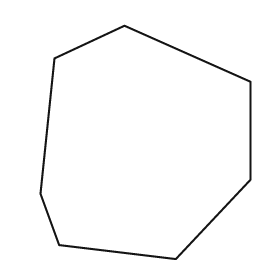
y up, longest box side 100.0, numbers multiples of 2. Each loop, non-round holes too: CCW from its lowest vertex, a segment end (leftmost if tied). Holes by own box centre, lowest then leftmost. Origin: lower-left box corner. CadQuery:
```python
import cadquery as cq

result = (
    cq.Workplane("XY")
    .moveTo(58.0, 0.0)
    .lineTo(90.0, 34.0)
    .lineTo(90.0, 76.0)
    .lineTo(36.0, 100.0)
    .lineTo(6.0, 86.0)
    .lineTo(0.0, 28.0)
    .lineTo(8.0, 6.0)
    .close()
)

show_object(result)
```